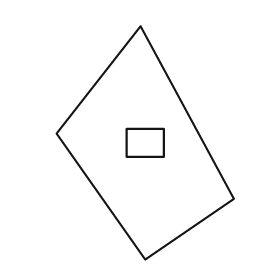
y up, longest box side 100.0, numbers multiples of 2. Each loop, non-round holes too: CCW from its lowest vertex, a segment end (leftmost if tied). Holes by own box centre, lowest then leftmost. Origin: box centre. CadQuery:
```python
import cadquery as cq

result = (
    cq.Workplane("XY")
    .moveTo(0.0, -50.0)
    .lineTo(38.0, -24.0)
    .lineTo(-2.0, 50.0)
    .lineTo(-38.0, 4.0)
    .close()
    .moveTo(-8.0, -6.0)
    .lineTo(8.0, -6.0)
    .lineTo(8.0, 6.0)
    .lineTo(-8.0, 6.0)
    .close()
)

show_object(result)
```